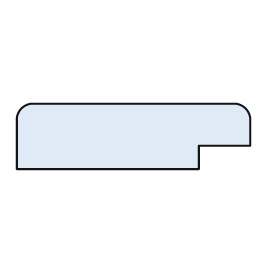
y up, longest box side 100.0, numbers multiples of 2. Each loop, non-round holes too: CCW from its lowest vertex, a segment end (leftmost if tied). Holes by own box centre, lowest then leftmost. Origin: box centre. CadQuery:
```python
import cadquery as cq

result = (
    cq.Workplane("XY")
    .moveTo(-50.0, -14.0)
    .lineTo(28.0, -14.0)
    .lineTo(28.0, -4.0)
    .lineTo(50.0, -4.0)
    .lineTo(50.0, 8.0)
    .threePointArc((48.0, 12.0), (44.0, 14.0))
    .lineTo(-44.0, 14.0)
    .threePointArc((-48.0, 12.0), (-50.0, 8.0))
    .close()
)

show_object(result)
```